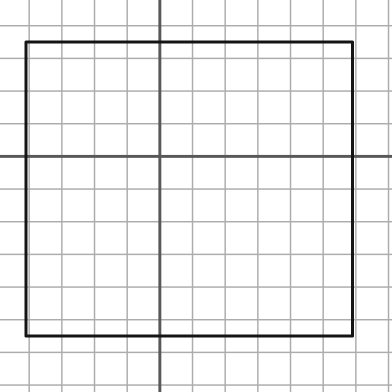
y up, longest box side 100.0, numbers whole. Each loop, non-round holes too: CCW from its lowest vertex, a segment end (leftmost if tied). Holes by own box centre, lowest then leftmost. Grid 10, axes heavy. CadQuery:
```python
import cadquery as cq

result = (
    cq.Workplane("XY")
    .moveTo(-41.0, -55.0)
    .lineTo(59.0, -55.0)
    .lineTo(59.0, 35.0)
    .lineTo(-41.0, 35.0)
    .close()
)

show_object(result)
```